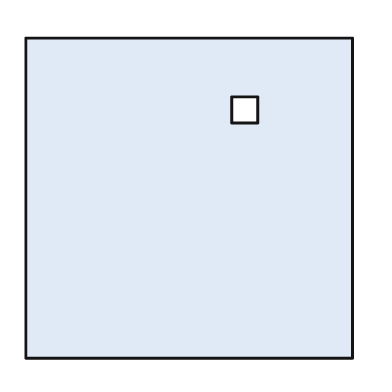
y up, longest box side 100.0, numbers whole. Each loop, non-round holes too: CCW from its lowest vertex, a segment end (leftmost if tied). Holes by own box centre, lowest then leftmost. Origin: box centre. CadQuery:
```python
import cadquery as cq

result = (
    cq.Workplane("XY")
    .moveTo(-50.0, -49.0)
    .lineTo(50.0, -49.0)
    .lineTo(50.0, 49.0)
    .lineTo(-50.0, 49.0)
    .close()
    .moveTo(13.0, 23.0)
    .lineTo(21.0, 23.0)
    .lineTo(21.0, 31.0)
    .lineTo(13.0, 31.0)
    .close()
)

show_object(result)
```